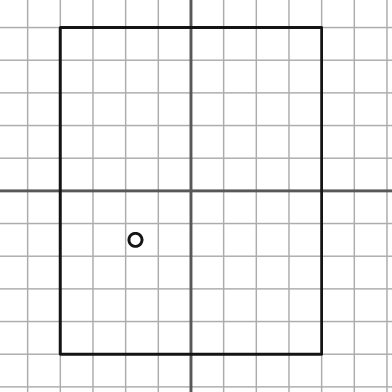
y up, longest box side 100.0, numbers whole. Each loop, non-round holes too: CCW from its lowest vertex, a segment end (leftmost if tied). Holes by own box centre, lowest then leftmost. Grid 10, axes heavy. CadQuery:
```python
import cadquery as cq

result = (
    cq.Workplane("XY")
    .moveTo(-40.0, -50.0)
    .lineTo(40.0, -50.0)
    .lineTo(40.0, 50.0)
    .lineTo(-40.0, 50.0)
    .close()
    .moveTo(-17.0, -15.0)
    .circle(2.0)
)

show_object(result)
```